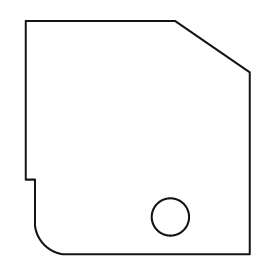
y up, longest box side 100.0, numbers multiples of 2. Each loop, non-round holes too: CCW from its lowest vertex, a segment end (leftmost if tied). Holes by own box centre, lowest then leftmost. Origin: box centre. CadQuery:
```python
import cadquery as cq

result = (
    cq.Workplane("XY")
    .moveTo(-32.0, -50.0)
    .lineTo(48.0, -50.0)
    .lineTo(48.0, 28.0)
    .lineTo(16.0, 50.0)
    .lineTo(-48.0, 50.0)
    .lineTo(-48.0, -18.0)
    .lineTo(-44.0, -18.0)
    .lineTo(-44.0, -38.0)
    .threePointArc((-40.0, -46.0), (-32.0, -50.0))
    .close()
    .moveTo(14.0, -34.0)
    .circle(8.0)
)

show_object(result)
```